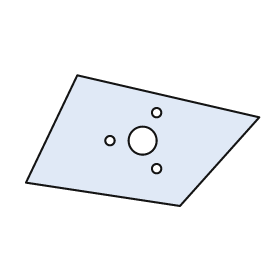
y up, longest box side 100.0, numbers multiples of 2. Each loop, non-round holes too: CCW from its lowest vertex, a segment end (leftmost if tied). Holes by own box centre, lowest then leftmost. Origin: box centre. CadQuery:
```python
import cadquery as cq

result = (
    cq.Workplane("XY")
    .moveTo(16.0, -28.0)
    .lineTo(50.0, 10.0)
    .lineTo(-28.0, 28.0)
    .lineTo(-50.0, -18.0)
    .close()
    .moveTo(6.0, -12.0)
    .circle(2.0)
    .moveTo(-14.0, 0.0)
    .circle(2.0)
    .moveTo(0.0, 0.0)
    .circle(6.0)
    .moveTo(6.0, 12.0)
    .circle(2.0)
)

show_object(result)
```